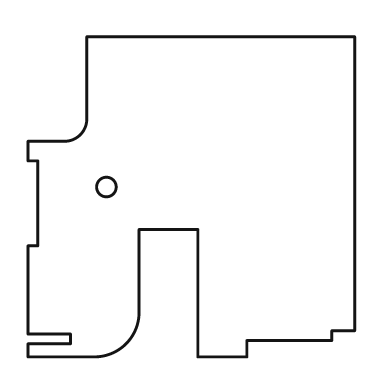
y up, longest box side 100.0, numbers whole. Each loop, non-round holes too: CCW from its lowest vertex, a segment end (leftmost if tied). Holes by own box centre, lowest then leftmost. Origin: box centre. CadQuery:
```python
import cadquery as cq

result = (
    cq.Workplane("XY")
    .moveTo(-50.0, -49.0)
    .lineTo(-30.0, -49.0)
    .threePointArc((-20.0, -45.0), (-16.0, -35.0))
    .lineTo(-16.0, -10.0)
    .lineTo(2.0, -10.0)
    .lineTo(2.0, -49.0)
    .lineTo(17.0, -49.0)
    .lineTo(17.0, -44.0)
    .lineTo(43.0, -44.0)
    .lineTo(43.0, -41.0)
    .lineTo(50.0, -41.0)
    .lineTo(50.0, 49.0)
    .lineTo(-32.0, 49.0)
    .lineTo(-32.0, 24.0)
    .threePointArc((-34.0, 19.0), (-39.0, 17.0))
    .lineTo(-50.0, 17.0)
    .lineTo(-50.0, 11.0)
    .lineTo(-47.0, 11.0)
    .lineTo(-47.0, -15.0)
    .lineTo(-50.0, -15.0)
    .lineTo(-50.0, -42.0)
    .lineTo(-37.0, -42.0)
    .lineTo(-37.0, -45.0)
    .lineTo(-50.0, -45.0)
    .close()
    .moveTo(-26.0, 3.0)
    .circle(3.0)
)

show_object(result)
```